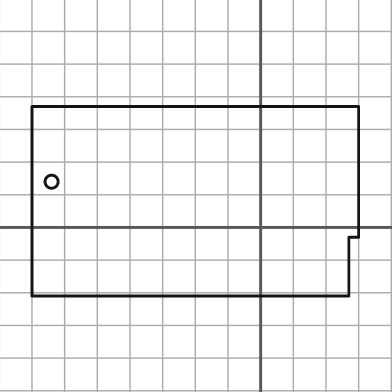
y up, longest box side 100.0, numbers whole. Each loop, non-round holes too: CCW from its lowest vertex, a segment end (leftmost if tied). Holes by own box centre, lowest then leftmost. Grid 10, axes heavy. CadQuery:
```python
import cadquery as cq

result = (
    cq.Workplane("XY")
    .moveTo(-70.0, -21.0)
    .lineTo(27.0, -21.0)
    .lineTo(27.0, -3.0)
    .lineTo(30.0, -3.0)
    .lineTo(30.0, 37.0)
    .lineTo(-70.0, 37.0)
    .close()
    .moveTo(-64.0, 14.0)
    .circle(2.0)
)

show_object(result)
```